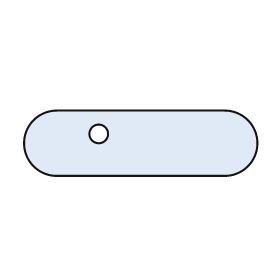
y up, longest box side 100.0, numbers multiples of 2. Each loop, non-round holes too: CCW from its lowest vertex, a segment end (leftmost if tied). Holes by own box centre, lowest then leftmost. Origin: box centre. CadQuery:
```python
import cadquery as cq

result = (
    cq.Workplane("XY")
    .moveTo(-36.0, -14.0)
    .lineTo(36.0, -14.0)
    .threePointArc((50.0, 0.0), (36.0, 14.0))
    .lineTo(-36.0, 14.0)
    .threePointArc((-50.0, 0.0), (-36.0, -14.0))
    .close()
    .moveTo(-18.0, 4.0)
    .circle(4.0)
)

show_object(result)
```